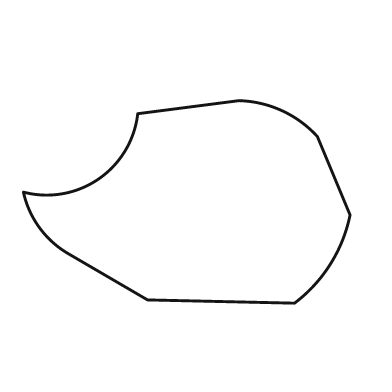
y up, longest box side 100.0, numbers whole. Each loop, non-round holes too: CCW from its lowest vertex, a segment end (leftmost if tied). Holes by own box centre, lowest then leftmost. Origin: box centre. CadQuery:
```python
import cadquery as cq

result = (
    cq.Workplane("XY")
    .moveTo(33.0, -31.0)
    .threePointArc((44.0, -19.0), (50.0, -4.0))
    .lineTo(40.0, 20.0)
    .threePointArc((29.0, 28.0), (16.0, 31.0))
    .lineTo(-15.0, 27.0)
    .threePointArc((-27.0, 7.0), (-50.0, 3.0))
    .threePointArc((-45.0, -8.0), (-36.0, -16.0))
    .lineTo(-12.0, -30.0)
    .close()
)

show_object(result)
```